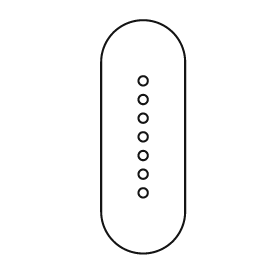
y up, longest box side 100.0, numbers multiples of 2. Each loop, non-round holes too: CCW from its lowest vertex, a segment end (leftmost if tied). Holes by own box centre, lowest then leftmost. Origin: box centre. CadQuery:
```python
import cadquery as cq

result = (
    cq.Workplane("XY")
    .moveTo(-18.0, -32.0)
    .threePointArc((0.0, -50.0), (18.0, -32.0))
    .lineTo(18.0, 32.0)
    .threePointArc((0.0, 50.0), (-18.0, 32.0))
    .close()
    .moveTo(0.0, -24.0)
    .circle(2.0)
    .moveTo(0.0, -16.0)
    .circle(2.0)
    .moveTo(0.0, -8.0)
    .circle(2.0)
    .moveTo(0.0, 0.0)
    .circle(2.0)
    .moveTo(0.0, 8.0)
    .circle(2.0)
    .moveTo(0.0, 16.0)
    .circle(2.0)
    .moveTo(0.0, 24.0)
    .circle(2.0)
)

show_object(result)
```